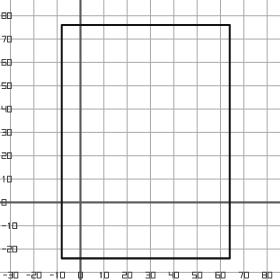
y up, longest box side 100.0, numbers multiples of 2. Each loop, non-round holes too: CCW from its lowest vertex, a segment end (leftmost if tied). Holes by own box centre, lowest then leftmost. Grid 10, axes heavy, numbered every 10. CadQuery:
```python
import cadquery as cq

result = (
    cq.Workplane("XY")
    .moveTo(-8.0, -24.0)
    .lineTo(64.0, -24.0)
    .lineTo(64.0, 76.0)
    .lineTo(-8.0, 76.0)
    .close()
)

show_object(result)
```